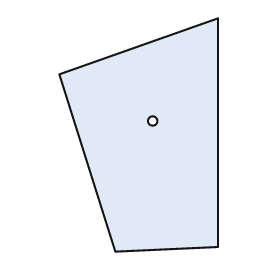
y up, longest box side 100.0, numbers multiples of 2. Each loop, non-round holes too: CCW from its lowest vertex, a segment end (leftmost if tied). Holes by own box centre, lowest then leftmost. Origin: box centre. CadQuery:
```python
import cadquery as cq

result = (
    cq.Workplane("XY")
    .moveTo(-10.0, -50.0)
    .lineTo(34.0, -48.0)
    .lineTo(34.0, 50.0)
    .lineTo(-34.0, 26.0)
    .close()
    .moveTo(6.0, 6.0)
    .circle(2.0)
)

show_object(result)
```